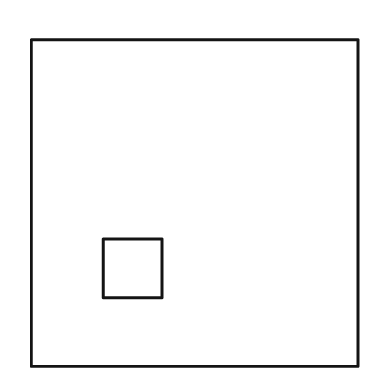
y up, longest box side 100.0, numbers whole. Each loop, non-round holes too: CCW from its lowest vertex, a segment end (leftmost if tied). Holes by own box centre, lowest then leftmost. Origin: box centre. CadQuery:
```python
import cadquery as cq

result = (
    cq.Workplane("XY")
    .moveTo(-50.0, -50.0)
    .lineTo(50.0, -50.0)
    .lineTo(50.0, 50.0)
    .lineTo(-50.0, 50.0)
    .close()
    .moveTo(-28.0, -29.0)
    .lineTo(-10.0, -29.0)
    .lineTo(-10.0, -11.0)
    .lineTo(-28.0, -11.0)
    .close()
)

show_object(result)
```